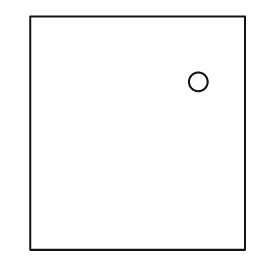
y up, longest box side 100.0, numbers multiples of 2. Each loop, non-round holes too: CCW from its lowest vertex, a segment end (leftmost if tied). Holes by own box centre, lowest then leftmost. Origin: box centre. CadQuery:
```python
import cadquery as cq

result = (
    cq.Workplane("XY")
    .moveTo(-46.0, -50.0)
    .lineTo(46.0, -50.0)
    .lineTo(46.0, 50.0)
    .lineTo(-46.0, 50.0)
    .close()
    .moveTo(26.0, 22.0)
    .circle(4.0)
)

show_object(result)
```